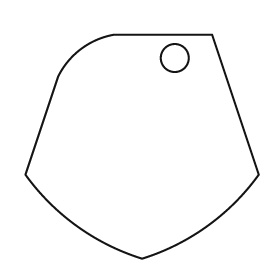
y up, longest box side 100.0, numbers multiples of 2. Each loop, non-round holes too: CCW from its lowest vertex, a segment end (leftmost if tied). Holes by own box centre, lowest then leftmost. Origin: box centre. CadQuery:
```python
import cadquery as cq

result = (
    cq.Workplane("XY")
    .moveTo(0.0, -48.0)
    .threePointArc((28.0, -34.0), (50.0, -12.0))
    .lineTo(30.0, 48.0)
    .lineTo(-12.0, 48.0)
    .threePointArc((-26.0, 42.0), (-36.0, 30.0))
    .lineTo(-50.0, -12.0)
    .threePointArc((-28.0, -34.0), (0.0, -48.0))
    .close()
    .moveTo(14.0, 38.0)
    .circle(6.0)
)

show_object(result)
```